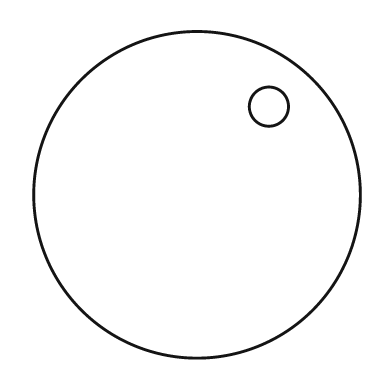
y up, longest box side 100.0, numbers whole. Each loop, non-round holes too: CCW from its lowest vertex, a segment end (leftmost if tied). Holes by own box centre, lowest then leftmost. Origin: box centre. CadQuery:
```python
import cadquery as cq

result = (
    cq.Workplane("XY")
    .moveTo(0.0, 0.0)
    .circle(50.0)
    .moveTo(22.0, 27.0)
    .circle(6.0)
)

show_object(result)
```